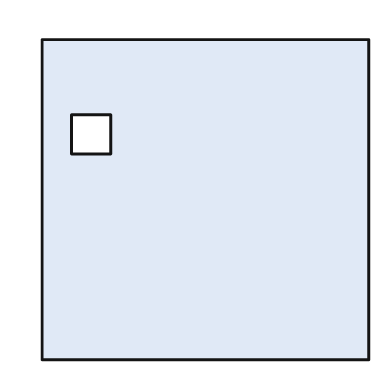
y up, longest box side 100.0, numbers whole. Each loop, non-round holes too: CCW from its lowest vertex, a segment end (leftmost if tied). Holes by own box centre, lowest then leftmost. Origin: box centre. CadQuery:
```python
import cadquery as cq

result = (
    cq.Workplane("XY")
    .moveTo(-50.0, -49.0)
    .lineTo(50.0, -49.0)
    .lineTo(50.0, 49.0)
    .lineTo(-50.0, 49.0)
    .close()
    .moveTo(-41.0, 14.0)
    .lineTo(-29.0, 14.0)
    .lineTo(-29.0, 26.0)
    .lineTo(-41.0, 26.0)
    .close()
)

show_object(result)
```